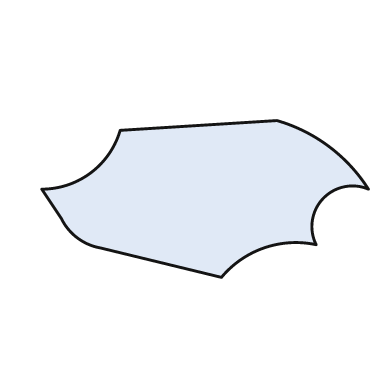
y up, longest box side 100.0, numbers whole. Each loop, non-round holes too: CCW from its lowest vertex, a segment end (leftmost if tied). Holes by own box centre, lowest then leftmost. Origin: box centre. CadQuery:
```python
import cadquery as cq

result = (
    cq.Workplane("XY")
    .moveTo(5.0, -24.0)
    .threePointArc((18.0, -15.0), (34.0, -14.0))
    .threePointArc((36.0, 0.0), (50.0, 3.0))
    .threePointArc((38.0, 16.0), (22.0, 24.0))
    .lineTo(-26.0, 21.0)
    .threePointArc((-35.0, 8.0), (-50.0, 3.0))
    .lineTo(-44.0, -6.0)
    .threePointArc((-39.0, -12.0), (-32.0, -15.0))
    .close()
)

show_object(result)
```